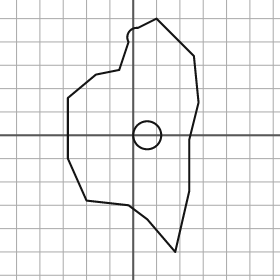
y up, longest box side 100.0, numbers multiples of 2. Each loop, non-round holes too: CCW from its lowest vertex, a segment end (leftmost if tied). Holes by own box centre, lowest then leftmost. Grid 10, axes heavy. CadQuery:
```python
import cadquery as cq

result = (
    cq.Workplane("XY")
    .moveTo(18.0, -50.0)
    .lineTo(24.0, -24.0)
    .lineTo(24.0, -2.0)
    .lineTo(28.0, 14.0)
    .lineTo(26.0, 34.0)
    .lineTo(10.0, 50.0)
    .lineTo(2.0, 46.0)
    .threePointArc((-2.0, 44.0), (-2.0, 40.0))
    .lineTo(-6.0, 28.0)
    .lineTo(-16.0, 26.0)
    .lineTo(-28.0, 16.0)
    .lineTo(-28.0, -10.0)
    .lineTo(-20.0, -28.0)
    .lineTo(-2.0, -30.0)
    .lineTo(6.0, -36.0)
    .close()
    .moveTo(6.0, 0.0)
    .circle(6.0)
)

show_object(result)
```